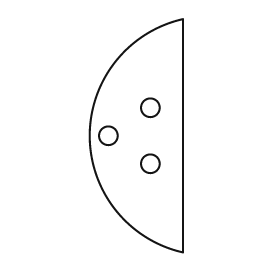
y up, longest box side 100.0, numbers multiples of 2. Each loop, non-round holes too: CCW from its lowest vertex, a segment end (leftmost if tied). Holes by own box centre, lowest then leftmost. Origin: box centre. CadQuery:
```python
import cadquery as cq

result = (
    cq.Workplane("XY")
    .moveTo(20.0, -50.0)
    .lineTo(20.0, 50.0)
    .threePointArc((-20.0, 0.0), (20.0, -50.0))
    .close()
    .moveTo(6.0, -12.0)
    .circle(4.0)
    .moveTo(-12.0, 0.0)
    .circle(4.0)
    .moveTo(6.0, 12.0)
    .circle(4.0)
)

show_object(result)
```